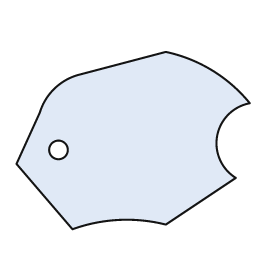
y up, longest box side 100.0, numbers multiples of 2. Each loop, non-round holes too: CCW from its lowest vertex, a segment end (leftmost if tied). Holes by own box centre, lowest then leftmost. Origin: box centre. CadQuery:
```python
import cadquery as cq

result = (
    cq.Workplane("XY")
    .moveTo(-26.0, -38.0)
    .threePointArc((-6.0, -34.0), (14.0, -36.0))
    .lineTo(44.0, -16.0)
    .threePointArc((36.0, 2.0), (50.0, 16.0))
    .threePointArc((34.0, 30.0), (14.0, 38.0))
    .lineTo(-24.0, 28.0)
    .threePointArc((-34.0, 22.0), (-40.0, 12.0))
    .lineTo(-50.0, -10.0)
    .close()
    .moveTo(-32.0, -4.0)
    .circle(4.0)
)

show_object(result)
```